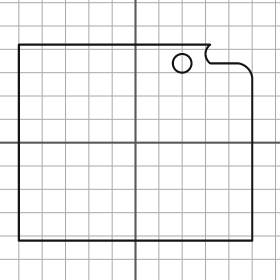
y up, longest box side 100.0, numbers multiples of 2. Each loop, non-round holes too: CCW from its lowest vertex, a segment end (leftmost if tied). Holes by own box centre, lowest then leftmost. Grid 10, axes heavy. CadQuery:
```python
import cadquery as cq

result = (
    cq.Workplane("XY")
    .moveTo(-50.0, -42.0)
    .lineTo(50.0, -42.0)
    .lineTo(50.0, 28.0)
    .threePointArc((48.0, 32.0), (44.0, 34.0))
    .lineTo(32.0, 34.0)
    .threePointArc((30.0, 38.0), (32.0, 42.0))
    .lineTo(-50.0, 42.0)
    .close()
    .moveTo(20.0, 34.0)
    .circle(4.0)
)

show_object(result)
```